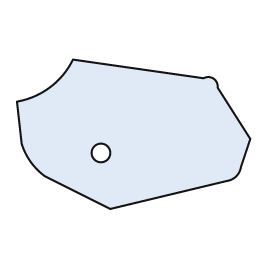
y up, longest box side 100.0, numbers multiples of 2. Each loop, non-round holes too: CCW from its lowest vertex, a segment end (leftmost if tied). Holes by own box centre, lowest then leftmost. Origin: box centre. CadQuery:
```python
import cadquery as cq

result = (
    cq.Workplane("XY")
    .moveTo(-10.0, -32.0)
    .lineTo(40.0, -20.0)
    .threePointArc((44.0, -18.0), (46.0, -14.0))
    .lineTo(50.0, -2.0)
    .lineTo(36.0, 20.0)
    .threePointArc((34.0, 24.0), (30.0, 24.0))
    .lineTo(-26.0, 32.0)
    .threePointArc((-36.0, 20.0), (-50.0, 14.0))
    .lineTo(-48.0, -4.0)
    .threePointArc((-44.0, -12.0), (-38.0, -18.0))
    .close()
    .moveTo(-14.0, -8.0)
    .circle(4.0)
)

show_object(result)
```